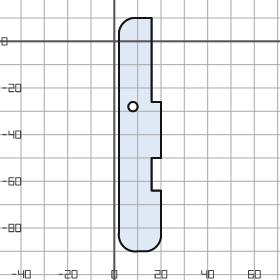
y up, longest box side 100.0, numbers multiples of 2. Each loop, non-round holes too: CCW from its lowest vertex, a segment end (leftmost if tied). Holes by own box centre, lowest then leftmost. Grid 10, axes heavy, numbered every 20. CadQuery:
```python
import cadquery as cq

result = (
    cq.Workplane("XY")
    .moveTo(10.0, -90.0)
    .lineTo(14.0, -90.0)
    .threePointArc((18.0, -88.0), (20.0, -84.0))
    .lineTo(20.0, -64.0)
    .lineTo(16.0, -64.0)
    .lineTo(16.0, -50.0)
    .lineTo(20.0, -50.0)
    .lineTo(20.0, -26.0)
    .lineTo(16.0, -26.0)
    .lineTo(16.0, 10.0)
    .lineTo(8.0, 10.0)
    .threePointArc((4.0, 8.0), (2.0, 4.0))
    .lineTo(2.0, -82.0)
    .threePointArc((4.0, -88.0), (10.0, -90.0))
    .close()
    .moveTo(8.0, -28.0)
    .circle(2.0)
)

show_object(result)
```